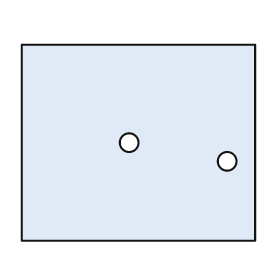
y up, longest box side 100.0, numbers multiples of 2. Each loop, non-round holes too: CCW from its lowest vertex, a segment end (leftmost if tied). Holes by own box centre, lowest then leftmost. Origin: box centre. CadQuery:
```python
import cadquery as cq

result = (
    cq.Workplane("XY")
    .moveTo(-50.0, -42.0)
    .lineTo(50.0, -42.0)
    .lineTo(50.0, 42.0)
    .lineTo(-50.0, 42.0)
    .close()
    .moveTo(38.0, -8.0)
    .circle(4.0)
    .moveTo(-4.0, 0.0)
    .circle(4.0)
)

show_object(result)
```